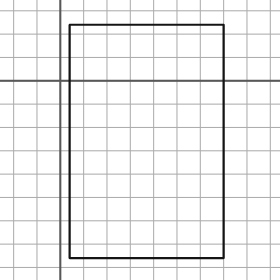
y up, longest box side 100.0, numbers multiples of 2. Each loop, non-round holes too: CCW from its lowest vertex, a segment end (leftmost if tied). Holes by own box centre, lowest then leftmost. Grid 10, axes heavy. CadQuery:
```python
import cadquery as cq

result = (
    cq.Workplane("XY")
    .moveTo(4.0, -76.0)
    .lineTo(70.0, -76.0)
    .lineTo(70.0, 24.0)
    .lineTo(4.0, 24.0)
    .close()
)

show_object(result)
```